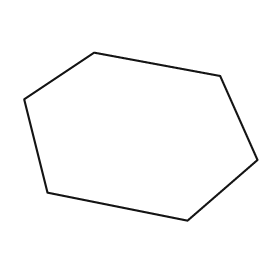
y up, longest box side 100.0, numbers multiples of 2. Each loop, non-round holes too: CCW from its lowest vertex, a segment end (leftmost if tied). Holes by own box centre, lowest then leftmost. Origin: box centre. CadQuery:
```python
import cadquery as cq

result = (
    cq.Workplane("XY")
    .moveTo(20.0, -36.0)
    .lineTo(50.0, -10.0)
    .lineTo(34.0, 26.0)
    .lineTo(-20.0, 36.0)
    .lineTo(-50.0, 16.0)
    .lineTo(-40.0, -24.0)
    .close()
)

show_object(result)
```